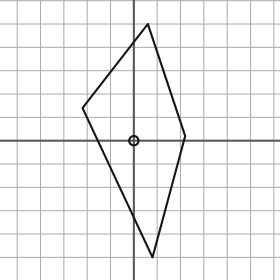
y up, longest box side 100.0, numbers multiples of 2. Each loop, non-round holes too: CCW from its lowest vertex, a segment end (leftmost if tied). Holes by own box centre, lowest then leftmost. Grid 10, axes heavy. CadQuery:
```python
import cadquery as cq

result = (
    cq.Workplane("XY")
    .moveTo(8.0, -50.0)
    .lineTo(22.0, 2.0)
    .lineTo(6.0, 50.0)
    .lineTo(-22.0, 14.0)
    .close()
    .moveTo(0.0, 0.0)
    .circle(2.0)
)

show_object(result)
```